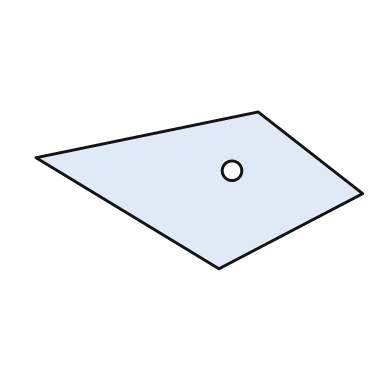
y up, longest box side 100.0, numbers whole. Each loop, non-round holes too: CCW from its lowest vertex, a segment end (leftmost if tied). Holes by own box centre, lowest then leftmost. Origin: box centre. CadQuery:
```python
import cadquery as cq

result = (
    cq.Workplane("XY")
    .moveTo(6.0, -24.0)
    .lineTo(50.0, -1.0)
    .lineTo(18.0, 24.0)
    .lineTo(-50.0, 10.0)
    .close()
    .moveTo(10.0, 6.0)
    .circle(3.0)
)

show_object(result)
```